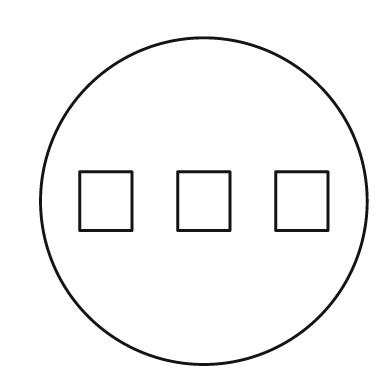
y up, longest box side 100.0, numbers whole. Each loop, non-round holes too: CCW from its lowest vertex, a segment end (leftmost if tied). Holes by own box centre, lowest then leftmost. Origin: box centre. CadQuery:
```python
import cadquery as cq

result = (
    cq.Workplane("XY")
    .moveTo(0.0, 0.0)
    .circle(50.0)
    .moveTo(-38.0, -9.0)
    .lineTo(-22.0, -9.0)
    .lineTo(-22.0, 9.0)
    .lineTo(-38.0, 9.0)
    .close()
    .moveTo(-8.0, -9.0)
    .lineTo(8.0, -9.0)
    .lineTo(8.0, 9.0)
    .lineTo(-8.0, 9.0)
    .close()
    .moveTo(22.0, -9.0)
    .lineTo(38.0, -9.0)
    .lineTo(38.0, 9.0)
    .lineTo(22.0, 9.0)
    .close()
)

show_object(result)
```